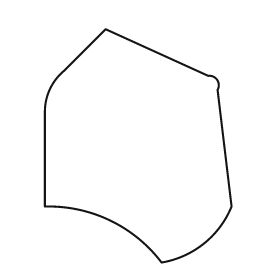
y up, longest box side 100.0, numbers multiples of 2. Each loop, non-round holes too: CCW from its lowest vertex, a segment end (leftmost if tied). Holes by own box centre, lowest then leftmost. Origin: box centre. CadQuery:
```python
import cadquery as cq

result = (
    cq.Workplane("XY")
    .moveTo(10.0, -50.0)
    .threePointArc((28.0, -42.0), (40.0, -26.0))
    .lineTo(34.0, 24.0)
    .threePointArc((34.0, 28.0), (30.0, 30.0))
    .lineTo(-14.0, 50.0)
    .lineTo(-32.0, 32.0)
    .threePointArc((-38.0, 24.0), (-40.0, 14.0))
    .lineTo(-40.0, -26.0)
    .threePointArc((-12.0, -32.0), (10.0, -50.0))
    .close()
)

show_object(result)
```